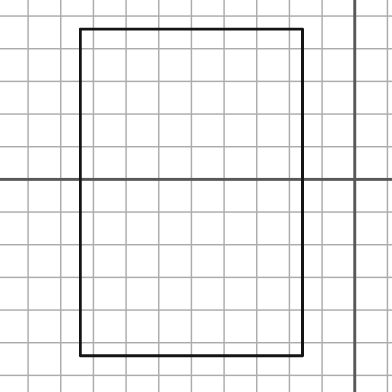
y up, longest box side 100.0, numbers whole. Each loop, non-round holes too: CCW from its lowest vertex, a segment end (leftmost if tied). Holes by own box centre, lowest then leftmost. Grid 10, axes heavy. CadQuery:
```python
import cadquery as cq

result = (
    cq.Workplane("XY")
    .moveTo(-84.0, -54.0)
    .lineTo(-16.0, -54.0)
    .lineTo(-16.0, 46.0)
    .lineTo(-84.0, 46.0)
    .close()
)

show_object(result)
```